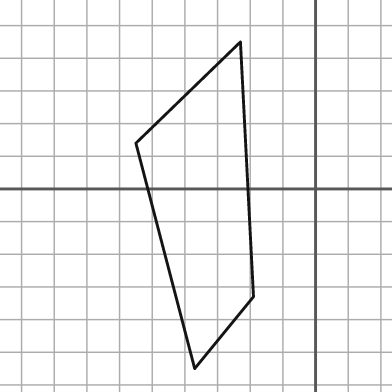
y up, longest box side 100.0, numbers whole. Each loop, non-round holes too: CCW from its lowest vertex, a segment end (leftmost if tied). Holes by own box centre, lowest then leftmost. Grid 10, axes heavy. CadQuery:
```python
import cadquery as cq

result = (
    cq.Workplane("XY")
    .moveTo(-37.0, -55.0)
    .lineTo(-19.0, -33.0)
    .lineTo(-23.0, 45.0)
    .lineTo(-55.0, 14.0)
    .close()
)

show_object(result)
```